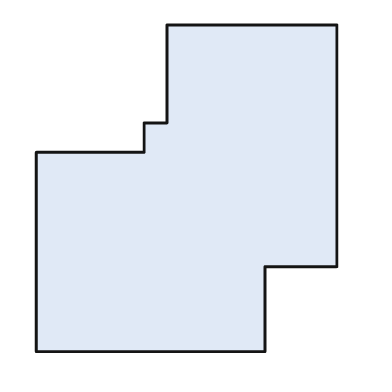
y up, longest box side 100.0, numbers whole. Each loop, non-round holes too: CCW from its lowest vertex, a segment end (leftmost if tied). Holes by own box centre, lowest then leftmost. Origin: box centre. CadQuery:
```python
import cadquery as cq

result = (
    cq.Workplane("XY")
    .moveTo(-46.0, -50.0)
    .lineTo(24.0, -50.0)
    .lineTo(24.0, -24.0)
    .lineTo(46.0, -24.0)
    .lineTo(46.0, 50.0)
    .lineTo(-6.0, 50.0)
    .lineTo(-6.0, 20.0)
    .lineTo(-13.0, 20.0)
    .lineTo(-13.0, 11.0)
    .lineTo(-46.0, 11.0)
    .close()
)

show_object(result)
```